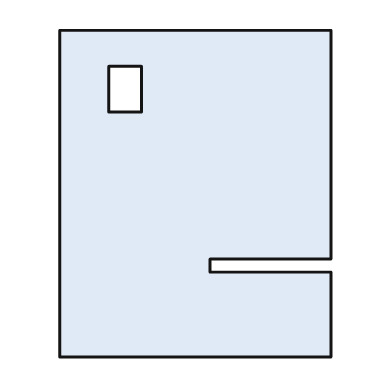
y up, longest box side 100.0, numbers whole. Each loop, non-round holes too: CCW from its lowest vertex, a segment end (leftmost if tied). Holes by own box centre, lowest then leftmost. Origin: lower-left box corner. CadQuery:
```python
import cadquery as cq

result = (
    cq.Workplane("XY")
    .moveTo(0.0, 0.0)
    .lineTo(83.0, 0.0)
    .lineTo(83.0, 26.0)
    .lineTo(46.0, 26.0)
    .lineTo(46.0, 30.0)
    .lineTo(83.0, 30.0)
    .lineTo(83.0, 100.0)
    .lineTo(0.0, 100.0)
    .close()
    .moveTo(15.0, 75.0)
    .lineTo(25.0, 75.0)
    .lineTo(25.0, 89.0)
    .lineTo(15.0, 89.0)
    .close()
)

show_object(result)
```